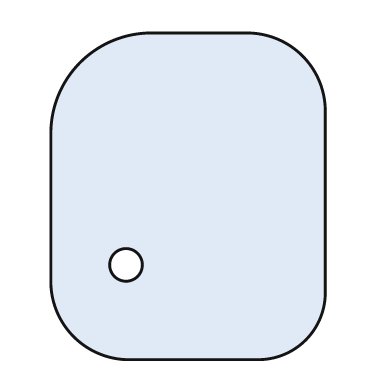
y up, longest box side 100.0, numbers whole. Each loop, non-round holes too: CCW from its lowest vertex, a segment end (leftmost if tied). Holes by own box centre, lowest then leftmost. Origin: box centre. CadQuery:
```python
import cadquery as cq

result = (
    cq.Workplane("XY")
    .moveTo(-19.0, -50.0)
    .lineTo(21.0, -50.0)
    .threePointArc((36.0, -44.0), (42.0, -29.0))
    .lineTo(42.0, 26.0)
    .threePointArc((35.0, 43.0), (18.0, 50.0))
    .lineTo(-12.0, 50.0)
    .threePointArc((-33.0, 41.0), (-42.0, 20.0))
    .lineTo(-42.0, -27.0)
    .threePointArc((-35.0, -43.0), (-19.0, -50.0))
    .close()
    .moveTo(-19.0, -21.0)
    .circle(5.0)
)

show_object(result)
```